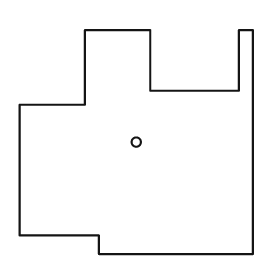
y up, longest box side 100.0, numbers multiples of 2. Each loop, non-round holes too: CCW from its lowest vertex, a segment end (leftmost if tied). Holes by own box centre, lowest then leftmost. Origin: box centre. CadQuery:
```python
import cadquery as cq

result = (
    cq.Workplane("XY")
    .moveTo(-16.0, -48.0)
    .lineTo(50.0, -48.0)
    .lineTo(50.0, 48.0)
    .lineTo(44.0, 48.0)
    .lineTo(44.0, 22.0)
    .lineTo(6.0, 22.0)
    .lineTo(6.0, 48.0)
    .lineTo(-22.0, 48.0)
    .lineTo(-22.0, 16.0)
    .lineTo(-50.0, 16.0)
    .lineTo(-50.0, -40.0)
    .lineTo(-16.0, -40.0)
    .close()
    .moveTo(0.0, 0.0)
    .circle(2.0)
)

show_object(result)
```